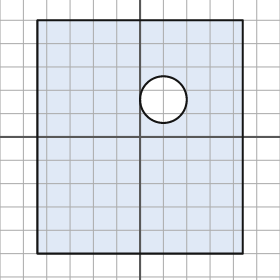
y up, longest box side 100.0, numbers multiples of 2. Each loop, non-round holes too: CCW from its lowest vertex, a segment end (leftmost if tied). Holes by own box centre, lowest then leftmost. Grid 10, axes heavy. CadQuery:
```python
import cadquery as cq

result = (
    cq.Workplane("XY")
    .moveTo(-44.0, -50.0)
    .lineTo(44.0, -50.0)
    .lineTo(44.0, 50.0)
    .lineTo(-44.0, 50.0)
    .close()
    .moveTo(10.0, 16.0)
    .circle(10.0)
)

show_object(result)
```